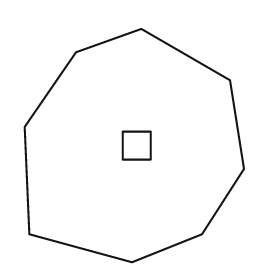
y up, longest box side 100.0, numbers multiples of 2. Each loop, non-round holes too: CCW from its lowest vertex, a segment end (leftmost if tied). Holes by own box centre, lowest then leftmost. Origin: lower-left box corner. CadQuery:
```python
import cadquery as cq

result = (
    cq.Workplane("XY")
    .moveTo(46.0, 0.0)
    .lineTo(76.0, 12.0)
    .lineTo(94.0, 40.0)
    .lineTo(88.0, 78.0)
    .lineTo(50.0, 100.0)
    .lineTo(22.0, 90.0)
    .lineTo(0.0, 58.0)
    .lineTo(2.0, 12.0)
    .close()
    .moveTo(42.0, 44.0)
    .lineTo(54.0, 44.0)
    .lineTo(54.0, 56.0)
    .lineTo(42.0, 56.0)
    .close()
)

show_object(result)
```